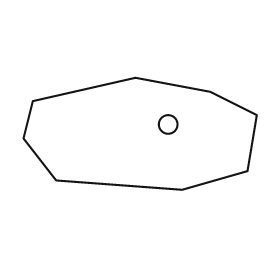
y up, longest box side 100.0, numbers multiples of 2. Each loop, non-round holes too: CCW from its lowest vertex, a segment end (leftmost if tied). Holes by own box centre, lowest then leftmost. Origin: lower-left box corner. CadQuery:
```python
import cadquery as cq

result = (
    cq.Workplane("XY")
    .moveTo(68.0, 0.0)
    .lineTo(96.0, 8.0)
    .lineTo(100.0, 32.0)
    .lineTo(80.0, 42.0)
    .lineTo(48.0, 48.0)
    .lineTo(4.0, 38.0)
    .lineTo(0.0, 22.0)
    .lineTo(14.0, 4.0)
    .close()
    .moveTo(62.0, 28.0)
    .circle(4.0)
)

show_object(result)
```